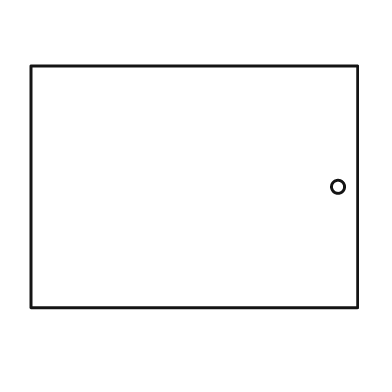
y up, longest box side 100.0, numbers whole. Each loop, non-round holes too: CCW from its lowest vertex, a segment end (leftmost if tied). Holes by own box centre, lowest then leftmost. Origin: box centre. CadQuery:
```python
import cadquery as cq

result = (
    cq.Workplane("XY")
    .moveTo(-50.0, -37.0)
    .lineTo(50.0, -37.0)
    .lineTo(50.0, 37.0)
    .lineTo(-50.0, 37.0)
    .close()
    .moveTo(44.0, 0.0)
    .circle(2.0)
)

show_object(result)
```